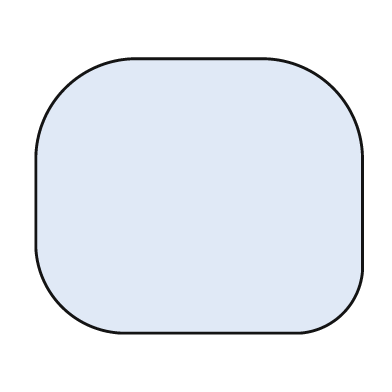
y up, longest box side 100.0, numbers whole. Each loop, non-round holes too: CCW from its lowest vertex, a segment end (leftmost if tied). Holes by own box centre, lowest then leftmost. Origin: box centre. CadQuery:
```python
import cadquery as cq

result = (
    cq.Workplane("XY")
    .moveTo(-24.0, -42.0)
    .lineTo(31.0, -42.0)
    .threePointArc((44.0, -36.0), (50.0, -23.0))
    .lineTo(50.0, 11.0)
    .threePointArc((41.0, 33.0), (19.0, 42.0))
    .lineTo(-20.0, 42.0)
    .threePointArc((-41.0, 33.0), (-50.0, 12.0))
    .lineTo(-50.0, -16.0)
    .threePointArc((-42.0, -34.0), (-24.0, -42.0))
    .close()
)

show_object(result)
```